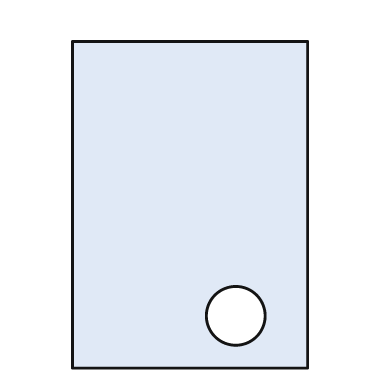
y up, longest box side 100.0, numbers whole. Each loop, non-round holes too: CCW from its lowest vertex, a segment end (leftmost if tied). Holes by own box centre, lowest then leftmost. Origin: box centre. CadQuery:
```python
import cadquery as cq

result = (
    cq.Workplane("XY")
    .moveTo(-36.0, -50.0)
    .lineTo(36.0, -50.0)
    .lineTo(36.0, 50.0)
    .lineTo(-36.0, 50.0)
    .close()
    .moveTo(14.0, -34.0)
    .circle(9.0)
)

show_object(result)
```